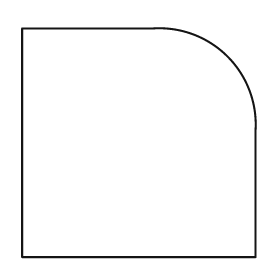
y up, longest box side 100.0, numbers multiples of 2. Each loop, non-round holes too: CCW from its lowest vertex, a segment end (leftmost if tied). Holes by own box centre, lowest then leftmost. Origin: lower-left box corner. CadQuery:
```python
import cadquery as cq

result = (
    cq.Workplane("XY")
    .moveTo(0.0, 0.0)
    .lineTo(100.0, 0.0)
    .lineTo(100.0, 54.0)
    .threePointArc((88.0, 86.0), (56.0, 98.0))
    .lineTo(0.0, 98.0)
    .close()
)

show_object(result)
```